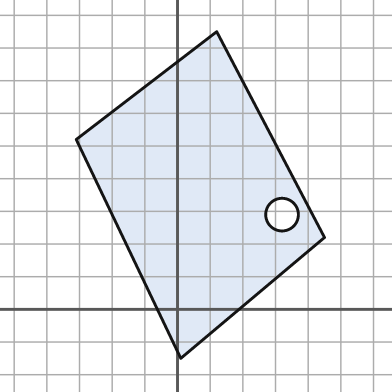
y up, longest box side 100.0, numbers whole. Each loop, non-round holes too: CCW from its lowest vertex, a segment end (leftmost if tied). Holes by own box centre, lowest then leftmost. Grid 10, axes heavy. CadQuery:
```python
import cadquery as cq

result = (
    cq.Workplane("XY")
    .moveTo(1.0, -15.0)
    .lineTo(45.0, 22.0)
    .lineTo(12.0, 85.0)
    .lineTo(-31.0, 52.0)
    .close()
    .moveTo(32.0, 29.0)
    .circle(5.0)
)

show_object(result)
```